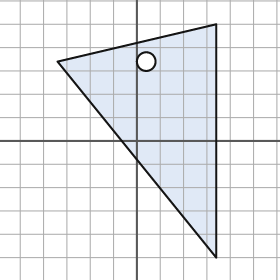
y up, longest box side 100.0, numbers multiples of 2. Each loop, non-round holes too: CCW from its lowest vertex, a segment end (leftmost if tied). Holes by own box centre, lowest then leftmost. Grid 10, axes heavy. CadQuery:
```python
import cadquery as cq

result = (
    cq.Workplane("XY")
    .moveTo(34.0, -50.0)
    .lineTo(34.0, 50.0)
    .lineTo(-34.0, 34.0)
    .close()
    .moveTo(4.0, 34.0)
    .circle(4.0)
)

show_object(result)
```